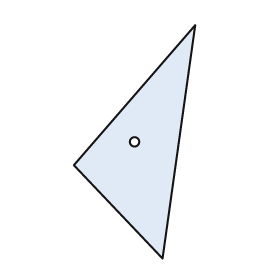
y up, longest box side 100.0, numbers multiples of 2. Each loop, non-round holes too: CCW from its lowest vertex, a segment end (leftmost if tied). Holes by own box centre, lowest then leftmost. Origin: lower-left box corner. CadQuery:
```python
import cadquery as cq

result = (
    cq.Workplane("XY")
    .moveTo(38.0, 0.0)
    .lineTo(52.0, 100.0)
    .lineTo(0.0, 40.0)
    .close()
    .moveTo(26.0, 50.0)
    .circle(2.0)
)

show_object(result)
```